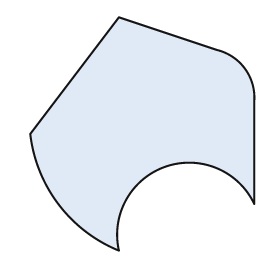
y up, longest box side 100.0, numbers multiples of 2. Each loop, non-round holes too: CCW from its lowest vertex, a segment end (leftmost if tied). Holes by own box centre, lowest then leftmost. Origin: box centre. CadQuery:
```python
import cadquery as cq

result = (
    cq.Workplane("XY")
    .moveTo(-10.0, -50.0)
    .threePointArc((10.0, -14.0), (48.0, -30.0))
    .lineTo(48.0, 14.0)
    .threePointArc((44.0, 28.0), (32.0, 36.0))
    .lineTo(-10.0, 50.0)
    .lineTo(-48.0, 0.0)
    .threePointArc((-36.0, -30.0), (-10.0, -50.0))
    .close()
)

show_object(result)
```